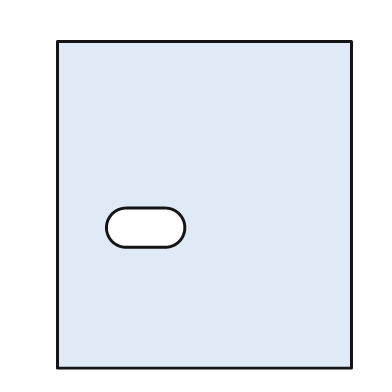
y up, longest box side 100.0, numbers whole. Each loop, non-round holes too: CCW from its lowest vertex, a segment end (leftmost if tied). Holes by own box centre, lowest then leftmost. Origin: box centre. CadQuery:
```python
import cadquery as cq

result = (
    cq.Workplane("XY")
    .moveTo(-45.0, -50.0)
    .lineTo(45.0, -50.0)
    .lineTo(45.0, 50.0)
    .lineTo(-45.0, 50.0)
    .close()
    .moveTo(-24.0, -13.0)
    .lineTo(-12.0, -13.0)
    .threePointArc((-6.0, -7.0), (-12.0, -1.0))
    .lineTo(-24.0, -1.0)
    .threePointArc((-30.0, -7.0), (-24.0, -13.0))
    .close()
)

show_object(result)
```